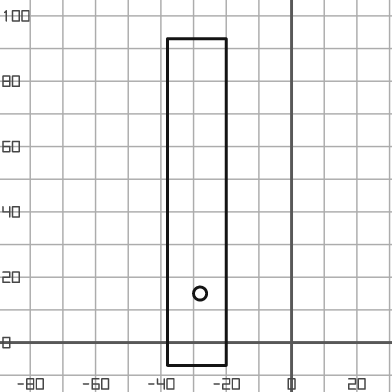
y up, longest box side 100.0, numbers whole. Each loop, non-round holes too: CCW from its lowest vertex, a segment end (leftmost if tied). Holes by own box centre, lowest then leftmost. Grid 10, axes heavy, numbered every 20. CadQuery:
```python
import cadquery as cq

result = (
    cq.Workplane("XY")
    .moveTo(-38.0, -7.0)
    .lineTo(-20.0, -7.0)
    .lineTo(-20.0, 93.0)
    .lineTo(-38.0, 93.0)
    .close()
    .moveTo(-28.0, 15.0)
    .circle(2.0)
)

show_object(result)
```